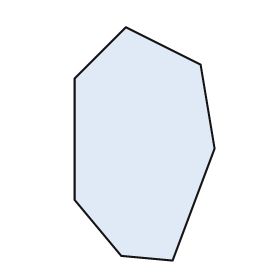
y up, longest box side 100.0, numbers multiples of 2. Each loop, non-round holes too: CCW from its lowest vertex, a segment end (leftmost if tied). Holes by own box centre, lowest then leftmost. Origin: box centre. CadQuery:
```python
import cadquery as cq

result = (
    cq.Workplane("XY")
    .moveTo(12.0, -50.0)
    .lineTo(30.0, -2.0)
    .lineTo(24.0, 34.0)
    .lineTo(-8.0, 50.0)
    .lineTo(-30.0, 28.0)
    .lineTo(-30.0, -24.0)
    .lineTo(-10.0, -48.0)
    .close()
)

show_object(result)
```